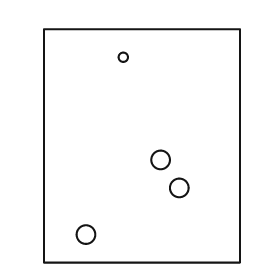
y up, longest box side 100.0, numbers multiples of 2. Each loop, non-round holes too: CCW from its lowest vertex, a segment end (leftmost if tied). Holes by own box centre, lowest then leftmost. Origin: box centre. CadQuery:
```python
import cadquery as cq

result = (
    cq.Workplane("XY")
    .moveTo(-42.0, -50.0)
    .lineTo(42.0, -50.0)
    .lineTo(42.0, 50.0)
    .lineTo(-42.0, 50.0)
    .close()
    .moveTo(-24.0, -38.0)
    .circle(4.0)
    .moveTo(16.0, -18.0)
    .circle(4.0)
    .moveTo(8.0, -6.0)
    .circle(4.0)
    .moveTo(-8.0, 38.0)
    .circle(2.0)
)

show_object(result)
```